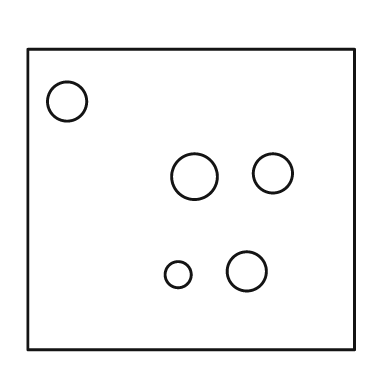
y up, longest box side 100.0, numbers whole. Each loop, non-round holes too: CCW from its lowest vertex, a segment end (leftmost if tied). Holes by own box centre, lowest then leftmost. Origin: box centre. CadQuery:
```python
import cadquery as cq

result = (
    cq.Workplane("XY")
    .moveTo(-50.0, -46.0)
    .lineTo(50.0, -46.0)
    .lineTo(50.0, 46.0)
    .lineTo(-50.0, 46.0)
    .close()
    .moveTo(-4.0, -23.0)
    .circle(4.0)
    .moveTo(17.0, -22.0)
    .circle(6.0)
    .moveTo(1.0, 7.0)
    .circle(7.0)
    .moveTo(25.0, 8.0)
    .circle(6.0)
    .moveTo(-38.0, 30.0)
    .circle(6.0)
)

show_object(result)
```